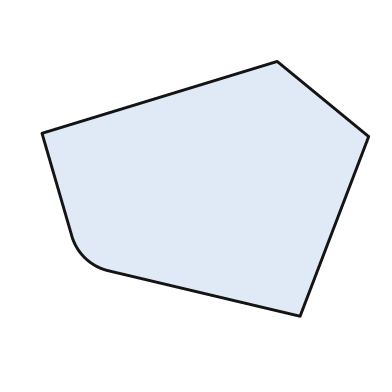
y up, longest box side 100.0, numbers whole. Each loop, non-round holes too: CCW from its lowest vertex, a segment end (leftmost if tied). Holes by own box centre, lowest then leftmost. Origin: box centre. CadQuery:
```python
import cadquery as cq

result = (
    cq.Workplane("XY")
    .moveTo(29.0, -39.0)
    .lineTo(50.0, 16.0)
    .lineTo(22.0, 39.0)
    .lineTo(-50.0, 17.0)
    .lineTo(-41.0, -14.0)
    .threePointArc((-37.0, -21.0), (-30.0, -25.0))
    .close()
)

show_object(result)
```